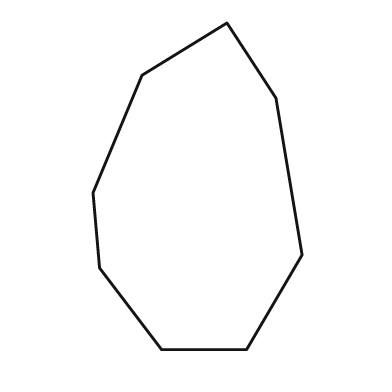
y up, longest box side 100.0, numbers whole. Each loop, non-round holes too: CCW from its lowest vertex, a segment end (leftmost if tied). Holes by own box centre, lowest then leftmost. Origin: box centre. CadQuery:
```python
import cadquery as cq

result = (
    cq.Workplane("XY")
    .moveTo(-11.0, -50.0)
    .lineTo(15.0, -50.0)
    .lineTo(32.0, -21.0)
    .lineTo(24.0, 27.0)
    .lineTo(9.0, 50.0)
    .lineTo(-17.0, 34.0)
    .lineTo(-32.0, -2.0)
    .lineTo(-30.0, -25.0)
    .close()
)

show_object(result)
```